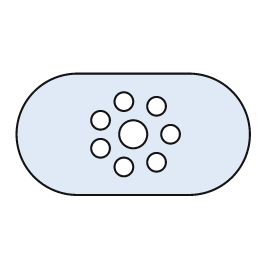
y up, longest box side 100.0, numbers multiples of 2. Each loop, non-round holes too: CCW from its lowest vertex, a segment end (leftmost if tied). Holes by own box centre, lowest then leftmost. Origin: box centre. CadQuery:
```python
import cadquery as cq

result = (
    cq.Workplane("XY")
    .moveTo(-24.0, -26.0)
    .lineTo(24.0, -26.0)
    .threePointArc((50.0, 0.0), (24.0, 26.0))
    .lineTo(-24.0, 26.0)
    .threePointArc((-50.0, 0.0), (-24.0, -26.0))
    .close()
    .moveTo(-4.0, -14.0)
    .circle(4.0)
    .moveTo(10.0, -12.0)
    .circle(4.0)
    .moveTo(-14.0, -6.0)
    .circle(4.0)
    .moveTo(0.0, 0.0)
    .circle(6.0)
    .moveTo(16.0, 0.0)
    .circle(4.0)
    .moveTo(-14.0, 6.0)
    .circle(4.0)
    .moveTo(10.0, 12.0)
    .circle(4.0)
    .moveTo(-4.0, 14.0)
    .circle(4.0)
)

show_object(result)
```